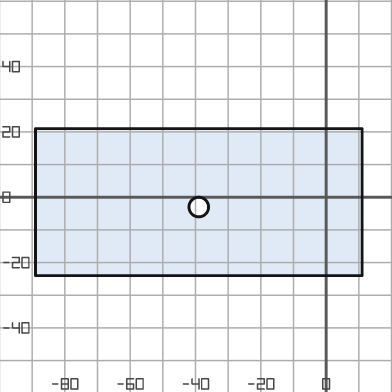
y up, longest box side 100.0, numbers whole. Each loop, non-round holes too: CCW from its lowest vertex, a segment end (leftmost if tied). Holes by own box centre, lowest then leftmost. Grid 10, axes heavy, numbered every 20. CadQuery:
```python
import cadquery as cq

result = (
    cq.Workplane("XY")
    .moveTo(-89.0, -24.0)
    .lineTo(11.0, -24.0)
    .lineTo(11.0, 21.0)
    .lineTo(-89.0, 21.0)
    .close()
    .moveTo(-39.0, -3.0)
    .circle(3.0)
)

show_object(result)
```